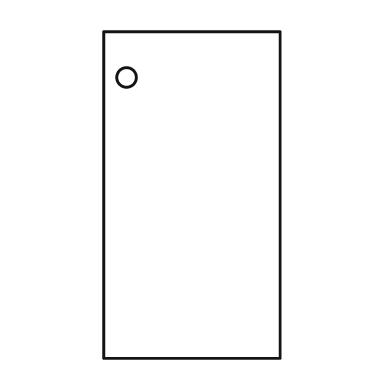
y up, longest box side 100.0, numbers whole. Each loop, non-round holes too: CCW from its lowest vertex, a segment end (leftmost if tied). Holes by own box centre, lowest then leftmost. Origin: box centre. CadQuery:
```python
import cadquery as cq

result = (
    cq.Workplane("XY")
    .moveTo(-27.0, -50.0)
    .lineTo(27.0, -50.0)
    .lineTo(27.0, 50.0)
    .lineTo(-27.0, 50.0)
    .close()
    .moveTo(-20.0, 36.0)
    .circle(3.0)
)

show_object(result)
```